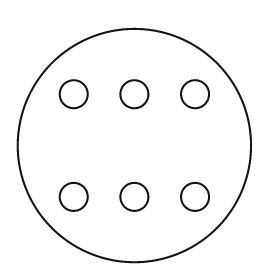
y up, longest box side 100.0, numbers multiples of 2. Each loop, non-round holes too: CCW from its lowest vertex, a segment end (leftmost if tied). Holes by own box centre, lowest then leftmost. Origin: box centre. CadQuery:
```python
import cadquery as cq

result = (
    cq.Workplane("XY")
    .moveTo(0.0, 0.0)
    .circle(50.0)
    .moveTo(-26.0, -22.0)
    .circle(6.0)
    .moveTo(0.0, -22.0)
    .circle(6.0)
    .moveTo(26.0, -22.0)
    .circle(6.0)
    .moveTo(-26.0, 22.0)
    .circle(6.0)
    .moveTo(0.0, 22.0)
    .circle(6.0)
    .moveTo(26.0, 22.0)
    .circle(6.0)
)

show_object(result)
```